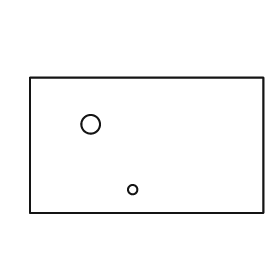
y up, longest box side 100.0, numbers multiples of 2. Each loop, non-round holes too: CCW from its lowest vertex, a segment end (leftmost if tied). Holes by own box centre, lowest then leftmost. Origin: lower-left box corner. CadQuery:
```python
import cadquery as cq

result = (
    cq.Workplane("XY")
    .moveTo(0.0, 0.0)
    .lineTo(100.0, 0.0)
    .lineTo(100.0, 58.0)
    .lineTo(0.0, 58.0)
    .close()
    .moveTo(44.0, 10.0)
    .circle(2.0)
    .moveTo(26.0, 38.0)
    .circle(4.0)
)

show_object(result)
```